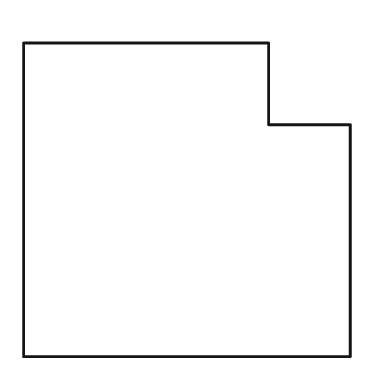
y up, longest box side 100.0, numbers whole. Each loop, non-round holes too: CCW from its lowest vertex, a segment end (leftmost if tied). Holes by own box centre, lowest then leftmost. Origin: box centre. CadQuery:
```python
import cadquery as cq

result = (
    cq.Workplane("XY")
    .moveTo(-50.0, -48.0)
    .lineTo(50.0, -48.0)
    .lineTo(50.0, 23.0)
    .lineTo(25.0, 23.0)
    .lineTo(25.0, 48.0)
    .lineTo(-50.0, 48.0)
    .close()
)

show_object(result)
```